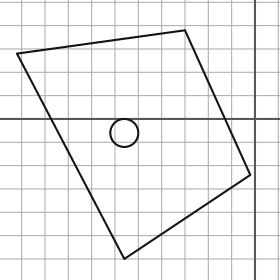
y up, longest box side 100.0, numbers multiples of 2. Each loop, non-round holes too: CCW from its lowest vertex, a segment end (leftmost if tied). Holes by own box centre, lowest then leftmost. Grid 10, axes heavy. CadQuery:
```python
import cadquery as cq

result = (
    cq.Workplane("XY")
    .moveTo(-56.0, -60.0)
    .lineTo(-2.0, -24.0)
    .lineTo(-30.0, 38.0)
    .lineTo(-102.0, 28.0)
    .close()
    .moveTo(-56.0, -6.0)
    .circle(6.0)
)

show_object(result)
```